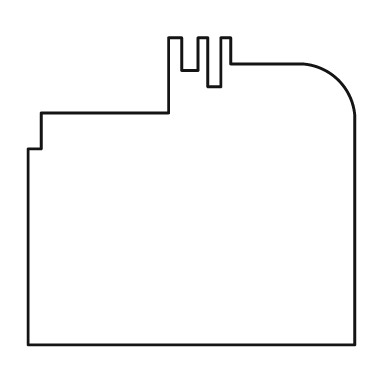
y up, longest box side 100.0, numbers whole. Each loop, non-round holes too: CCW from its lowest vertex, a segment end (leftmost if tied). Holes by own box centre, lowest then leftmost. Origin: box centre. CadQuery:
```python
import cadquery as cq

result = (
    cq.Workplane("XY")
    .moveTo(-50.0, -47.0)
    .lineTo(50.0, -47.0)
    .lineTo(50.0, 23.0)
    .threePointArc((45.0, 34.0), (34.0, 39.0))
    .lineTo(12.0, 39.0)
    .lineTo(12.0, 47.0)
    .lineTo(9.0, 47.0)
    .lineTo(9.0, 32.0)
    .lineTo(5.0, 32.0)
    .lineTo(5.0, 47.0)
    .lineTo(2.0, 47.0)
    .lineTo(2.0, 37.0)
    .lineTo(-3.0, 37.0)
    .lineTo(-3.0, 47.0)
    .lineTo(-7.0, 47.0)
    .lineTo(-7.0, 24.0)
    .lineTo(-46.0, 24.0)
    .lineTo(-46.0, 13.0)
    .lineTo(-50.0, 13.0)
    .close()
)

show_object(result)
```